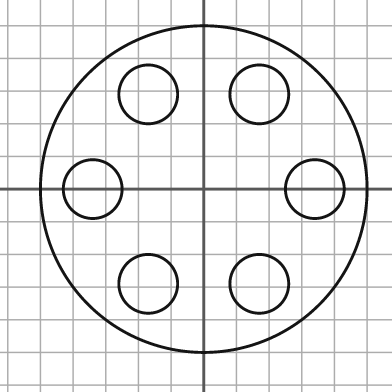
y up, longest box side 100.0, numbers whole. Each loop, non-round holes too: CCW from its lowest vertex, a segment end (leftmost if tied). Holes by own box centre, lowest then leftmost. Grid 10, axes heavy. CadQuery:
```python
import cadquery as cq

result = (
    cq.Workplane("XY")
    .moveTo(0.0, 0.0)
    .circle(50.0)
    .moveTo(-17.0, -29.0)
    .circle(9.0)
    .moveTo(17.0, -29.0)
    .circle(9.0)
    .moveTo(-34.0, 0.0)
    .circle(9.0)
    .moveTo(34.0, 0.0)
    .circle(9.0)
    .moveTo(-17.0, 29.0)
    .circle(9.0)
    .moveTo(17.0, 29.0)
    .circle(9.0)
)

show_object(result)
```